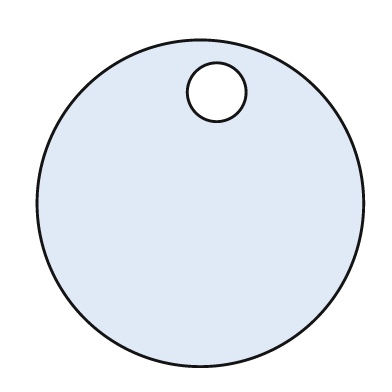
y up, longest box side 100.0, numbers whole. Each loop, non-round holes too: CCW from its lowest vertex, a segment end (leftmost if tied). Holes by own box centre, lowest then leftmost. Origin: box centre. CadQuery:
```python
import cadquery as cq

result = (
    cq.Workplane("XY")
    .moveTo(0.0, 0.0)
    .circle(50.0)
    .moveTo(5.0, 34.0)
    .circle(9.0)
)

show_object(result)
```